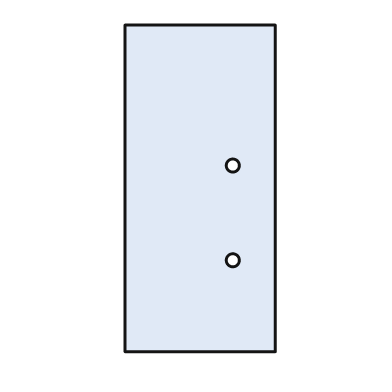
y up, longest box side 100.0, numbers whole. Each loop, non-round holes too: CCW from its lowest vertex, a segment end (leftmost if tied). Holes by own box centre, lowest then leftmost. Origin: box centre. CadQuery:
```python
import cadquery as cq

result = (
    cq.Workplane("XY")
    .moveTo(-23.0, -50.0)
    .lineTo(23.0, -50.0)
    .lineTo(23.0, 50.0)
    .lineTo(-23.0, 50.0)
    .close()
    .moveTo(10.0, -22.0)
    .circle(2.0)
    .moveTo(10.0, 7.0)
    .circle(2.0)
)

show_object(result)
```